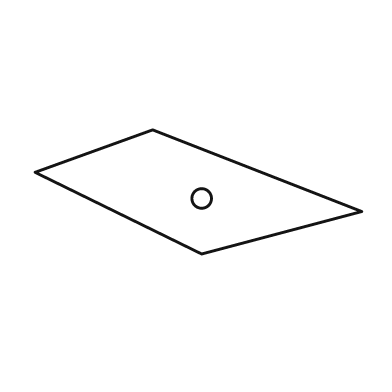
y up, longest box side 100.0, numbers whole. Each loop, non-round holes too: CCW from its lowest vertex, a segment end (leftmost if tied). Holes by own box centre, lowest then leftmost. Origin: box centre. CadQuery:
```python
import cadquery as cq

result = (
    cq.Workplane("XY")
    .moveTo(1.0, -19.0)
    .lineTo(50.0, -6.0)
    .lineTo(-14.0, 19.0)
    .lineTo(-50.0, 6.0)
    .close()
    .moveTo(1.0, -2.0)
    .circle(3.0)
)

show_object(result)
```